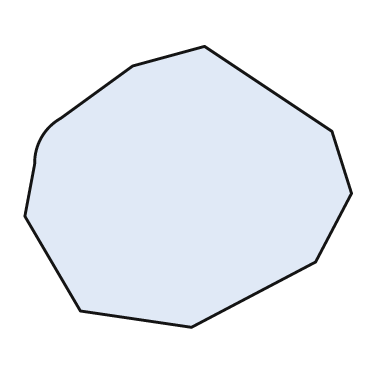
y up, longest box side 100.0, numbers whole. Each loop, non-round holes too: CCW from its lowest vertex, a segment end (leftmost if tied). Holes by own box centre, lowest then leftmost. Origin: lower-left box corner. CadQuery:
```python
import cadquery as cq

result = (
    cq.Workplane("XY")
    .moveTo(51.0, 0.0)
    .lineTo(89.0, 20.0)
    .lineTo(100.0, 41.0)
    .lineTo(94.0, 60.0)
    .lineTo(55.0, 86.0)
    .lineTo(33.0, 80.0)
    .lineTo(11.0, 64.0)
    .threePointArc((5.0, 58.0), (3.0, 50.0))
    .lineTo(0.0, 34.0)
    .lineTo(17.0, 5.0)
    .close()
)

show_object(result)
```